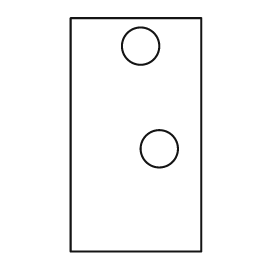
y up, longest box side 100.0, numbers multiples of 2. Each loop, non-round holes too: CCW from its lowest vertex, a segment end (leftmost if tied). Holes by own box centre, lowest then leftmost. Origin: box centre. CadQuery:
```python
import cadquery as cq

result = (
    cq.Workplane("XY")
    .moveTo(-28.0, -50.0)
    .lineTo(28.0, -50.0)
    .lineTo(28.0, 50.0)
    .lineTo(-28.0, 50.0)
    .close()
    .moveTo(10.0, -6.0)
    .circle(8.0)
    .moveTo(2.0, 38.0)
    .circle(8.0)
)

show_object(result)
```